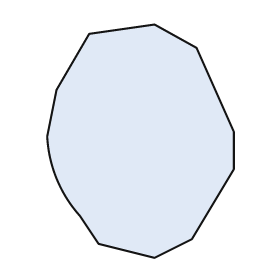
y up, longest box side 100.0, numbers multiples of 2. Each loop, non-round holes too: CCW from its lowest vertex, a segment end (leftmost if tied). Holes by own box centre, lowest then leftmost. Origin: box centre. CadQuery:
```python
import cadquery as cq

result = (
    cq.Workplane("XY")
    .moveTo(6.0, -50.0)
    .lineTo(22.0, -42.0)
    .lineTo(40.0, -12.0)
    .lineTo(40.0, 4.0)
    .lineTo(24.0, 40.0)
    .lineTo(6.0, 50.0)
    .lineTo(-22.0, 46.0)
    .lineTo(-36.0, 22.0)
    .lineTo(-40.0, 2.0)
    .threePointArc((-36.0, -16.0), (-26.0, -32.0))
    .lineTo(-18.0, -44.0)
    .close()
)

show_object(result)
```